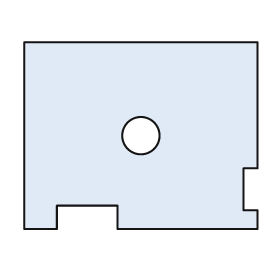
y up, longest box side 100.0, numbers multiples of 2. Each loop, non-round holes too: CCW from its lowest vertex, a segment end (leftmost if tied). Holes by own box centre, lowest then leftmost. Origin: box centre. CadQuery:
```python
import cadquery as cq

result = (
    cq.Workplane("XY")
    .moveTo(-50.0, -40.0)
    .lineTo(-36.0, -40.0)
    .lineTo(-36.0, -30.0)
    .lineTo(-10.0, -30.0)
    .lineTo(-10.0, -40.0)
    .lineTo(50.0, -40.0)
    .lineTo(50.0, -32.0)
    .lineTo(44.0, -32.0)
    .lineTo(44.0, -14.0)
    .lineTo(50.0, -14.0)
    .lineTo(50.0, 40.0)
    .lineTo(-50.0, 40.0)
    .close()
    .moveTo(0.0, 0.0)
    .circle(8.0)
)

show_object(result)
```